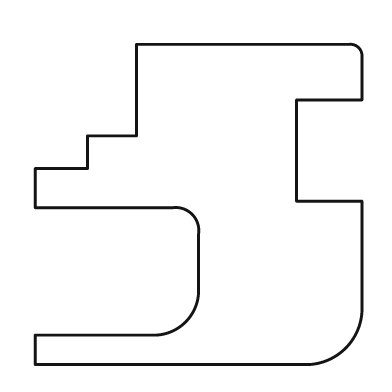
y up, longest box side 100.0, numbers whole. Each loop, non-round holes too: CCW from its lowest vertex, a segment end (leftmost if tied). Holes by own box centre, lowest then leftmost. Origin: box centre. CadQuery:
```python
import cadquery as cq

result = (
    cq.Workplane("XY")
    .moveTo(-50.0, -49.0)
    .lineTo(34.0, -49.0)
    .threePointArc((45.0, -44.0), (50.0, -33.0))
    .lineTo(50.0, 1.0)
    .lineTo(30.0, 1.0)
    .lineTo(30.0, 32.0)
    .lineTo(50.0, 32.0)
    .lineTo(50.0, 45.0)
    .threePointArc((49.0, 48.0), (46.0, 49.0))
    .lineTo(-19.0, 49.0)
    .lineTo(-19.0, 21.0)
    .lineTo(-34.0, 21.0)
    .lineTo(-34.0, 11.0)
    .lineTo(-50.0, 11.0)
    .lineTo(-50.0, -1.0)
    .lineTo(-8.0, -1.0)
    .threePointArc((-2.0, -3.0), (0.0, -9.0))
    .lineTo(0.0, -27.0)
    .threePointArc((-4.0, -36.0), (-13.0, -40.0))
    .lineTo(-50.0, -40.0)
    .close()
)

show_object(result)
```